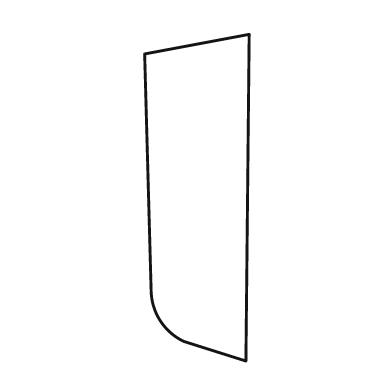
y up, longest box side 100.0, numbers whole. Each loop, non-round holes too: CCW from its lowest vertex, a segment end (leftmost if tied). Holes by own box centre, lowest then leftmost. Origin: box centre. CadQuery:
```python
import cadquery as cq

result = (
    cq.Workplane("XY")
    .moveTo(15.0, -50.0)
    .lineTo(16.0, 50.0)
    .lineTo(-16.0, 44.0)
    .lineTo(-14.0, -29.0)
    .threePointArc((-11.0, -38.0), (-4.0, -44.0))
    .close()
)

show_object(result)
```